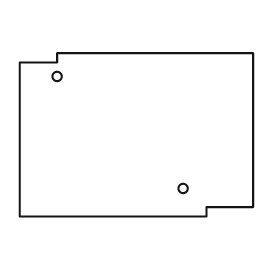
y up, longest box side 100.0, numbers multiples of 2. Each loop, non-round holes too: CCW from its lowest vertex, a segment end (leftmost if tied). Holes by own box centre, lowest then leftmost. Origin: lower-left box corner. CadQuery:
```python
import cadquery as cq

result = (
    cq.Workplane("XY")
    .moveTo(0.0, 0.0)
    .lineTo(80.0, 0.0)
    .lineTo(80.0, 4.0)
    .lineTo(100.0, 4.0)
    .lineTo(100.0, 70.0)
    .lineTo(16.0, 70.0)
    .lineTo(16.0, 66.0)
    .lineTo(0.0, 66.0)
    .close()
    .moveTo(70.0, 12.0)
    .circle(2.0)
    .moveTo(16.0, 60.0)
    .circle(2.0)
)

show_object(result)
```